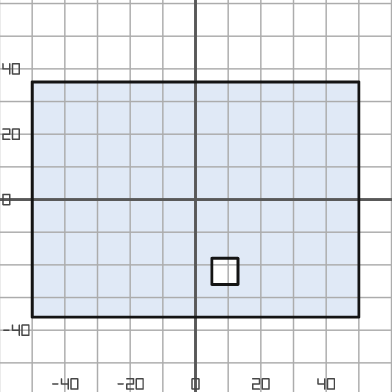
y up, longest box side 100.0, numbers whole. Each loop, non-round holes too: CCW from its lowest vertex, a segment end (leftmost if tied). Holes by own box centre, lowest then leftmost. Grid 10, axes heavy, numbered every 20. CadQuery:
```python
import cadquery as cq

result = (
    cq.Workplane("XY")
    .moveTo(-50.0, -36.0)
    .lineTo(50.0, -36.0)
    .lineTo(50.0, 36.0)
    .lineTo(-50.0, 36.0)
    .close()
    .moveTo(5.0, -26.0)
    .lineTo(13.0, -26.0)
    .lineTo(13.0, -18.0)
    .lineTo(5.0, -18.0)
    .close()
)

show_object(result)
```